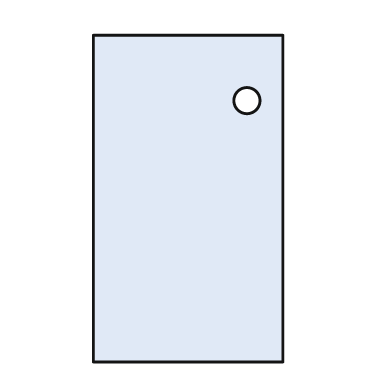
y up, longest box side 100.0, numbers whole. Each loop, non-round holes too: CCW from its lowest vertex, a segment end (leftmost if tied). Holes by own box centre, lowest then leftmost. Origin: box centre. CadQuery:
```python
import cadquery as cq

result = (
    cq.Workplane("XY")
    .moveTo(-29.0, -50.0)
    .lineTo(29.0, -50.0)
    .lineTo(29.0, 50.0)
    .lineTo(-29.0, 50.0)
    .close()
    .moveTo(18.0, 30.0)
    .circle(4.0)
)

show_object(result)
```